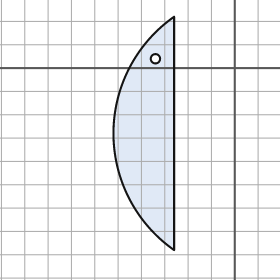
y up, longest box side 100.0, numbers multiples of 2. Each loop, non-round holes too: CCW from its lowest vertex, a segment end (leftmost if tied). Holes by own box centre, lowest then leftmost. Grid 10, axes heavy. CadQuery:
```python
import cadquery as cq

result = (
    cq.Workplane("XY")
    .moveTo(-26.0, -78.0)
    .lineTo(-26.0, 22.0)
    .threePointArc((-52.0, -28.0), (-26.0, -78.0))
    .close()
    .moveTo(-34.0, 4.0)
    .circle(2.0)
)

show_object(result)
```